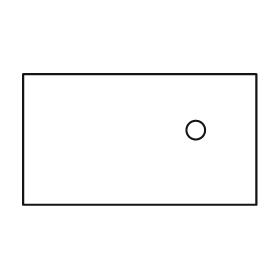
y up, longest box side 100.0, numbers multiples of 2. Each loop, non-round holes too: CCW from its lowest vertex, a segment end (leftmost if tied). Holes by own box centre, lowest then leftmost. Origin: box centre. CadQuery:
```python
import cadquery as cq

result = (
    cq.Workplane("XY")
    .moveTo(-50.0, -28.0)
    .lineTo(50.0, -28.0)
    .lineTo(50.0, 28.0)
    .lineTo(-50.0, 28.0)
    .close()
    .moveTo(24.0, 4.0)
    .circle(4.0)
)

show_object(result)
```